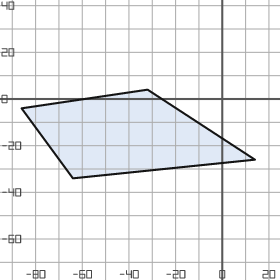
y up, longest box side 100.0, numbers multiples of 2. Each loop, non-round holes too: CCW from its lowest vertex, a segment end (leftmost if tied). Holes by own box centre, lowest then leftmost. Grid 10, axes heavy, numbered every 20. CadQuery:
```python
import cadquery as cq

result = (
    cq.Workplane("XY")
    .moveTo(-64.0, -34.0)
    .lineTo(14.0, -26.0)
    .lineTo(-32.0, 4.0)
    .lineTo(-86.0, -4.0)
    .close()
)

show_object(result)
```